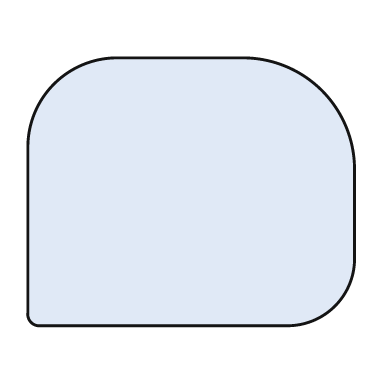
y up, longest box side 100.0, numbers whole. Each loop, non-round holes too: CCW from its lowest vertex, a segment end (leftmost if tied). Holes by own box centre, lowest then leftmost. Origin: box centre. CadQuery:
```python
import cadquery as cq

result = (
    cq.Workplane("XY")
    .moveTo(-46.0, -41.0)
    .lineTo(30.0, -41.0)
    .threePointArc((44.0, -35.0), (50.0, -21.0))
    .lineTo(50.0, 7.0)
    .threePointArc((40.0, 31.0), (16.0, 41.0))
    .lineTo(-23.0, 41.0)
    .threePointArc((-42.0, 33.0), (-50.0, 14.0))
    .lineTo(-50.0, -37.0)
    .threePointArc((-49.0, -40.0), (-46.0, -41.0))
    .close()
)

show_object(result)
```